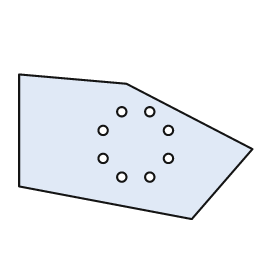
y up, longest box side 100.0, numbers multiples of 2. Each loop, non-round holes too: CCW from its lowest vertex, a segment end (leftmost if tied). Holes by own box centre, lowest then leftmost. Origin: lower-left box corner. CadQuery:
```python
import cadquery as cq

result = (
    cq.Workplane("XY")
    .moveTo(74.0, 0.0)
    .lineTo(100.0, 30.0)
    .lineTo(46.0, 58.0)
    .lineTo(0.0, 62.0)
    .lineTo(0.0, 14.0)
    .close()
    .moveTo(44.0, 18.0)
    .circle(2.0)
    .moveTo(56.0, 18.0)
    .circle(2.0)
    .moveTo(36.0, 26.0)
    .circle(2.0)
    .moveTo(64.0, 26.0)
    .circle(2.0)
    .moveTo(36.0, 38.0)
    .circle(2.0)
    .moveTo(64.0, 38.0)
    .circle(2.0)
    .moveTo(44.0, 46.0)
    .circle(2.0)
    .moveTo(56.0, 46.0)
    .circle(2.0)
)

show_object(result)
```